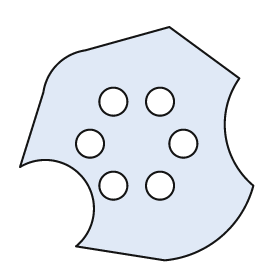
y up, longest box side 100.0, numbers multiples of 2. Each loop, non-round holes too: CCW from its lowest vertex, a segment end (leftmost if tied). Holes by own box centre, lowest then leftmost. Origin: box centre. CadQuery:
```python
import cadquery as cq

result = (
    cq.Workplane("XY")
    .moveTo(12.0, -50.0)
    .threePointArc((36.0, -40.0), (50.0, -18.0))
    .threePointArc((38.0, 4.0), (44.0, 28.0))
    .lineTo(14.0, 50.0)
    .lineTo(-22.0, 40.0)
    .threePointArc((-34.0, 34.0), (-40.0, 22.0))
    .lineTo(-50.0, -10.0)
    .threePointArc((-22.0, -16.0), (-26.0, -44.0))
    .close()
    .moveTo(-10.0, -18.0)
    .circle(6.0)
    .moveTo(10.0, -18.0)
    .circle(6.0)
    .moveTo(-20.0, 0.0)
    .circle(6.0)
    .moveTo(20.0, 0.0)
    .circle(6.0)
    .moveTo(-10.0, 18.0)
    .circle(6.0)
    .moveTo(10.0, 18.0)
    .circle(6.0)
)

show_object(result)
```